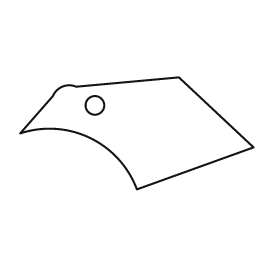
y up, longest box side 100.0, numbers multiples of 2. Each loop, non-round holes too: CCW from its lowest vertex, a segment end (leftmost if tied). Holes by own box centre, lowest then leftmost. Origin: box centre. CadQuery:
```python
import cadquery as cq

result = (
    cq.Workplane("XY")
    .moveTo(0.0, -24.0)
    .lineTo(50.0, -6.0)
    .lineTo(18.0, 24.0)
    .lineTo(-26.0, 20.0)
    .threePointArc((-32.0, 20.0), (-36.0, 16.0))
    .lineTo(-50.0, 0.0)
    .threePointArc((-20.0, -2.0), (0.0, -24.0))
    .close()
    .moveTo(-18.0, 12.0)
    .circle(4.0)
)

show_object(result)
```